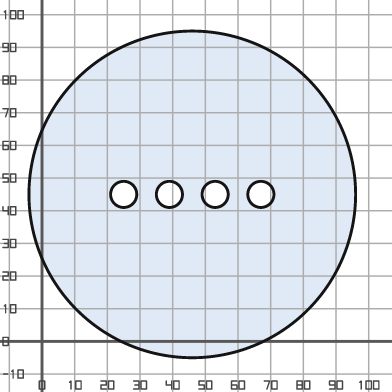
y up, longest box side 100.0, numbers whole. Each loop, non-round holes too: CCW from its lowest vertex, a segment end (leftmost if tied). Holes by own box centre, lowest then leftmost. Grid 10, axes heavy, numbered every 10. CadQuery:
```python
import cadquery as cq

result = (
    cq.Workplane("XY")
    .moveTo(46.0, 45.0)
    .circle(50.0)
    .moveTo(25.0, 45.0)
    .circle(4.0)
    .moveTo(39.0, 45.0)
    .circle(4.0)
    .moveTo(53.0, 45.0)
    .circle(4.0)
    .moveTo(67.0, 45.0)
    .circle(4.0)
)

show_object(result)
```